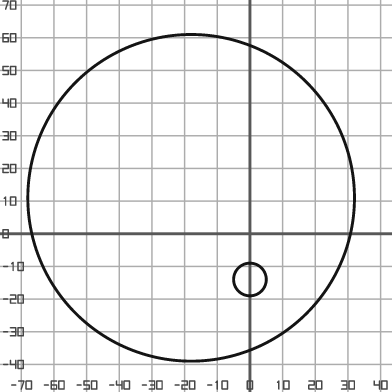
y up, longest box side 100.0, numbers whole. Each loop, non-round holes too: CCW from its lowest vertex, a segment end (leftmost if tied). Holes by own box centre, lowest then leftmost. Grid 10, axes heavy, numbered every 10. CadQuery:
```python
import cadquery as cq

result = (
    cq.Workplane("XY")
    .moveTo(-18.0, 11.0)
    .circle(50.0)
    .moveTo(0.0, -14.0)
    .circle(5.0)
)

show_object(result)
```